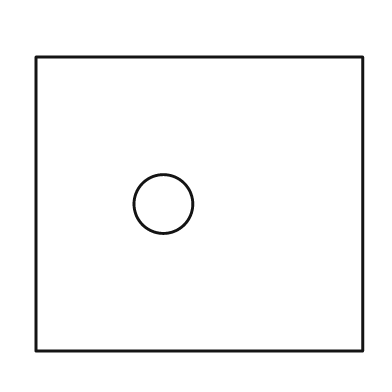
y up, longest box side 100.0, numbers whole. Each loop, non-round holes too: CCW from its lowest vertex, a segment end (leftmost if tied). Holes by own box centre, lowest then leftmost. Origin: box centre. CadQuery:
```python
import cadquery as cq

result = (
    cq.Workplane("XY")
    .moveTo(-50.0, -45.0)
    .lineTo(50.0, -45.0)
    .lineTo(50.0, 45.0)
    .lineTo(-50.0, 45.0)
    .close()
    .moveTo(-11.0, 0.0)
    .circle(9.0)
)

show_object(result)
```